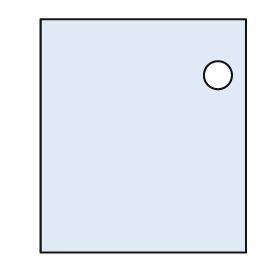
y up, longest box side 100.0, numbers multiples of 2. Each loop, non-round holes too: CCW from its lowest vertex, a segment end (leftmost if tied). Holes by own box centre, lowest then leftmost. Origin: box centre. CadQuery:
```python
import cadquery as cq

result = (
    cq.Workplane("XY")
    .moveTo(-44.0, -50.0)
    .lineTo(44.0, -50.0)
    .lineTo(44.0, 50.0)
    .lineTo(-44.0, 50.0)
    .close()
    .moveTo(32.0, 26.0)
    .circle(6.0)
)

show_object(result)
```